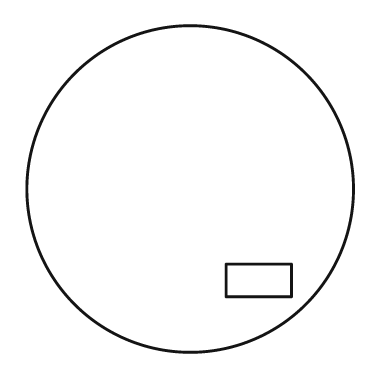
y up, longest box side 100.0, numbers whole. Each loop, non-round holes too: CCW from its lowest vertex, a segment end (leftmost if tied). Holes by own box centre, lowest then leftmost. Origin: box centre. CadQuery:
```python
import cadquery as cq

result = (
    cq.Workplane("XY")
    .moveTo(0.0, 0.0)
    .circle(50.0)
    .moveTo(11.0, -33.0)
    .lineTo(31.0, -33.0)
    .lineTo(31.0, -23.0)
    .lineTo(11.0, -23.0)
    .close()
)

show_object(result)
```